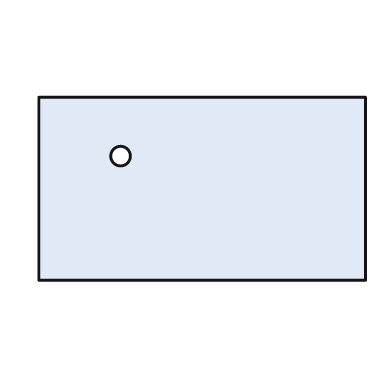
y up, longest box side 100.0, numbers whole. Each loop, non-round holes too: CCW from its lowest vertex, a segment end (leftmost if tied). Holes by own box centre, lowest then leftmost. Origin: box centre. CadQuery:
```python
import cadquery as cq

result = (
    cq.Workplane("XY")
    .moveTo(-50.0, -28.0)
    .lineTo(50.0, -28.0)
    .lineTo(50.0, 28.0)
    .lineTo(-50.0, 28.0)
    .close()
    .moveTo(-25.0, 10.0)
    .circle(3.0)
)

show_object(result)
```